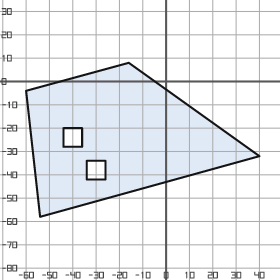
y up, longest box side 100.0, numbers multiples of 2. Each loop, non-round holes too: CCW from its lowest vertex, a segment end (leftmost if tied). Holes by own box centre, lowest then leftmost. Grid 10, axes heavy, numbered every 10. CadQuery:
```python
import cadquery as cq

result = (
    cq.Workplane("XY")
    .moveTo(-54.0, -58.0)
    .lineTo(40.0, -32.0)
    .lineTo(-16.0, 8.0)
    .lineTo(-60.0, -4.0)
    .close()
    .moveTo(-34.0, -42.0)
    .lineTo(-26.0, -42.0)
    .lineTo(-26.0, -34.0)
    .lineTo(-34.0, -34.0)
    .close()
    .moveTo(-44.0, -28.0)
    .lineTo(-36.0, -28.0)
    .lineTo(-36.0, -20.0)
    .lineTo(-44.0, -20.0)
    .close()
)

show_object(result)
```